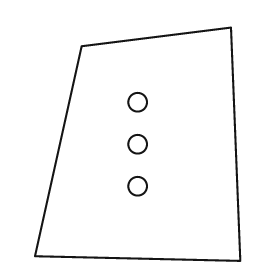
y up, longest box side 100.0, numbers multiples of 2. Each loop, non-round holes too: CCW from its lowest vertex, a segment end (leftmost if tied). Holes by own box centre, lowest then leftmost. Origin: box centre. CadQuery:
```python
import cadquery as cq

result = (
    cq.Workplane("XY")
    .moveTo(44.0, -50.0)
    .lineTo(40.0, 50.0)
    .lineTo(-24.0, 42.0)
    .lineTo(-44.0, -48.0)
    .close()
    .moveTo(0.0, -18.0)
    .circle(4.0)
    .moveTo(0.0, 0.0)
    .circle(4.0)
    .moveTo(0.0, 18.0)
    .circle(4.0)
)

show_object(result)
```